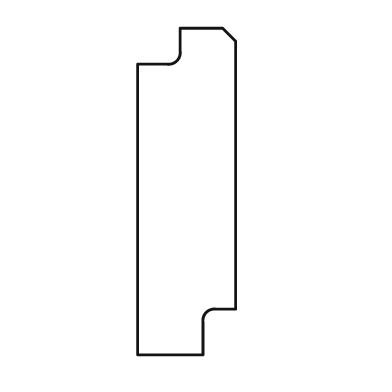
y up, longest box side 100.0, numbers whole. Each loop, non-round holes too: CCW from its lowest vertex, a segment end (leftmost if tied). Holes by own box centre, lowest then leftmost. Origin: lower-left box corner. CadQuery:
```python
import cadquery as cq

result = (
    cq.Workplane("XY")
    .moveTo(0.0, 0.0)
    .lineTo(20.0, 0.0)
    .lineTo(20.0, 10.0)
    .threePointArc((21.0, 13.0), (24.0, 14.0))
    .lineTo(30.0, 14.0)
    .lineTo(30.0, 96.0)
    .lineTo(26.0, 100.0)
    .lineTo(13.0, 100.0)
    .lineTo(13.0, 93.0)
    .threePointArc((12.0, 90.0), (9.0, 89.0))
    .lineTo(0.0, 89.0)
    .close()
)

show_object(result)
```